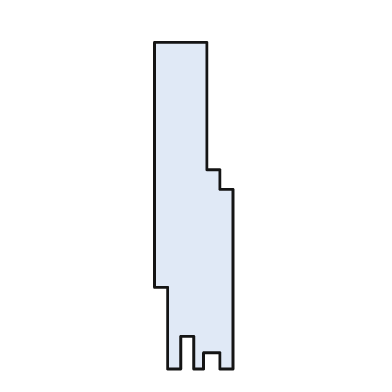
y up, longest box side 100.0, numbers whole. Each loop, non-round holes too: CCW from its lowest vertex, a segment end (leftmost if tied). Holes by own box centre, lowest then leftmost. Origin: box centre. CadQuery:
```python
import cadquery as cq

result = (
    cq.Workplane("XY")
    .moveTo(-8.0, -50.0)
    .lineTo(-4.0, -50.0)
    .lineTo(-4.0, -40.0)
    .lineTo(0.0, -40.0)
    .lineTo(0.0, -50.0)
    .lineTo(3.0, -50.0)
    .lineTo(3.0, -45.0)
    .lineTo(8.0, -45.0)
    .lineTo(8.0, -50.0)
    .lineTo(12.0, -50.0)
    .lineTo(12.0, 5.0)
    .lineTo(8.0, 5.0)
    .lineTo(8.0, 11.0)
    .lineTo(4.0, 11.0)
    .lineTo(4.0, 50.0)
    .lineTo(-12.0, 50.0)
    .lineTo(-12.0, -25.0)
    .lineTo(-8.0, -25.0)
    .close()
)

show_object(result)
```